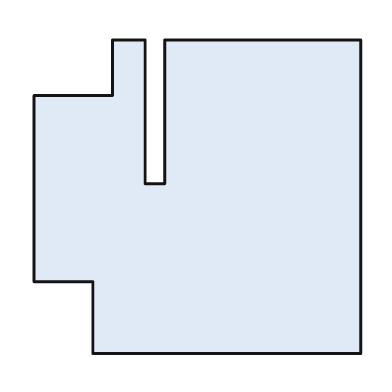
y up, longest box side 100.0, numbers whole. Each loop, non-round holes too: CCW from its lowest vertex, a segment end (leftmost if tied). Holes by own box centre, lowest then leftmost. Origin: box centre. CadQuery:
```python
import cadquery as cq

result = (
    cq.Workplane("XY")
    .moveTo(-32.0, -48.0)
    .lineTo(50.0, -48.0)
    .lineTo(50.0, 48.0)
    .lineTo(-10.0, 48.0)
    .lineTo(-10.0, 4.0)
    .lineTo(-16.0, 4.0)
    .lineTo(-16.0, 48.0)
    .lineTo(-26.0, 48.0)
    .lineTo(-26.0, 31.0)
    .lineTo(-50.0, 31.0)
    .lineTo(-50.0, -26.0)
    .lineTo(-32.0, -26.0)
    .close()
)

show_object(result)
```